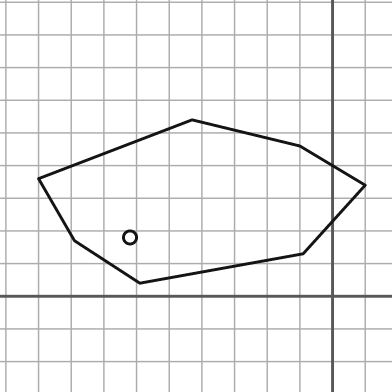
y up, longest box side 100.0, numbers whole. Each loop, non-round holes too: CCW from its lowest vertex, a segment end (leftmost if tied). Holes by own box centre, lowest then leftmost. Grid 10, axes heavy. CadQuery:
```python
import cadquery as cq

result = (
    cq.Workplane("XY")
    .moveTo(-59.0, 4.0)
    .lineTo(-9.0, 13.0)
    .lineTo(10.0, 34.0)
    .lineTo(-10.0, 46.0)
    .lineTo(-43.0, 54.0)
    .lineTo(-90.0, 36.0)
    .lineTo(-79.0, 17.0)
    .close()
    .moveTo(-62.0, 18.0)
    .circle(2.0)
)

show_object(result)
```